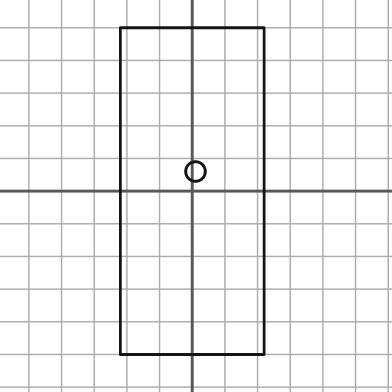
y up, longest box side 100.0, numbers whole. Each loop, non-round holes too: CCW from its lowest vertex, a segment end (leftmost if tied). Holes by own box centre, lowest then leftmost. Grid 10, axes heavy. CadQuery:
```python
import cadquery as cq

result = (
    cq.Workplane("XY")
    .moveTo(-22.0, -50.0)
    .lineTo(22.0, -50.0)
    .lineTo(22.0, 50.0)
    .lineTo(-22.0, 50.0)
    .close()
    .moveTo(1.0, 6.0)
    .circle(3.0)
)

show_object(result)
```